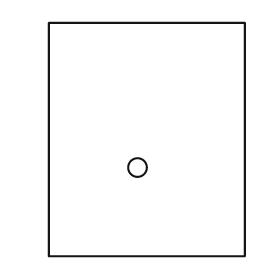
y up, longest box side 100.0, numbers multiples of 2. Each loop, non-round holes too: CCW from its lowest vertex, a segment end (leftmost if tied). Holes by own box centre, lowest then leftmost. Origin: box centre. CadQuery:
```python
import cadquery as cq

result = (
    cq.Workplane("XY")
    .moveTo(-42.0, -50.0)
    .lineTo(42.0, -50.0)
    .lineTo(42.0, 50.0)
    .lineTo(-42.0, 50.0)
    .close()
    .moveTo(-4.0, -12.0)
    .circle(4.0)
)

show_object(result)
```